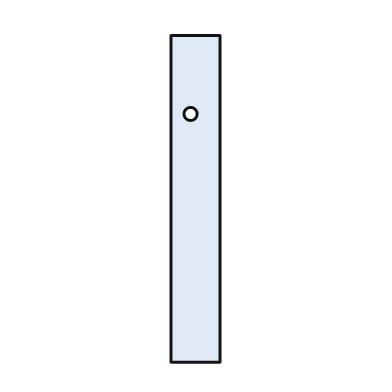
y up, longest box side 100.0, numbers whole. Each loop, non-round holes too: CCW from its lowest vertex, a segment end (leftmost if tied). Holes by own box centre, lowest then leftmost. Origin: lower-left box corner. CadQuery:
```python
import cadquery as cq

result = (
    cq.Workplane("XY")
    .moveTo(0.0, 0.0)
    .lineTo(15.0, 0.0)
    .lineTo(15.0, 100.0)
    .lineTo(0.0, 100.0)
    .close()
    .moveTo(6.0, 76.0)
    .circle(2.0)
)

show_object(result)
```